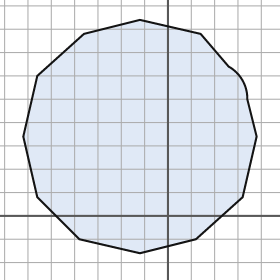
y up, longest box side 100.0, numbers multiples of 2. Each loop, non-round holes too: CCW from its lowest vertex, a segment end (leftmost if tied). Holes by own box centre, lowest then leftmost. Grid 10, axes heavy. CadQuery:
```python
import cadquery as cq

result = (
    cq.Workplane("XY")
    .moveTo(-12.0, -16.0)
    .lineTo(12.0, -10.0)
    .lineTo(32.0, 8.0)
    .lineTo(38.0, 34.0)
    .lineTo(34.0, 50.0)
    .threePointArc((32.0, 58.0), (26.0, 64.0))
    .lineTo(14.0, 78.0)
    .lineTo(-12.0, 84.0)
    .lineTo(-36.0, 78.0)
    .lineTo(-56.0, 60.0)
    .lineTo(-62.0, 34.0)
    .lineTo(-56.0, 8.0)
    .lineTo(-38.0, -10.0)
    .close()
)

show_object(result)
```